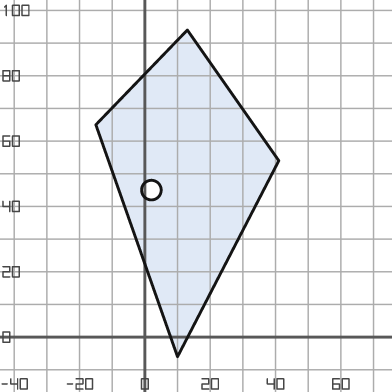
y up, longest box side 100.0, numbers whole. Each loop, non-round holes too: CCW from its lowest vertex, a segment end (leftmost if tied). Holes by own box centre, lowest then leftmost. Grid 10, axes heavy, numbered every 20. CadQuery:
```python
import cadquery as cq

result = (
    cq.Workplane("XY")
    .moveTo(10.0, -6.0)
    .lineTo(41.0, 54.0)
    .lineTo(13.0, 94.0)
    .lineTo(-15.0, 65.0)
    .close()
    .moveTo(2.0, 45.0)
    .circle(3.0)
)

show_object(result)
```